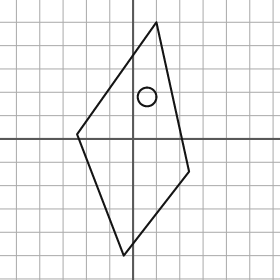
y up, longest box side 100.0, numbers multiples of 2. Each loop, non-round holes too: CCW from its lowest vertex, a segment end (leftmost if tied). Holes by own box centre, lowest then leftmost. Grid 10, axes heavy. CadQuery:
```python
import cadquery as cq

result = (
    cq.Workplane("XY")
    .moveTo(-4.0, -50.0)
    .lineTo(24.0, -14.0)
    .lineTo(10.0, 50.0)
    .lineTo(-24.0, 2.0)
    .close()
    .moveTo(6.0, 18.0)
    .circle(4.0)
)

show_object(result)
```